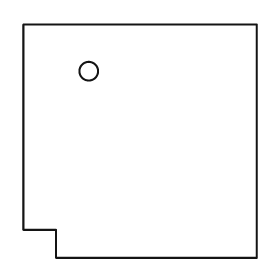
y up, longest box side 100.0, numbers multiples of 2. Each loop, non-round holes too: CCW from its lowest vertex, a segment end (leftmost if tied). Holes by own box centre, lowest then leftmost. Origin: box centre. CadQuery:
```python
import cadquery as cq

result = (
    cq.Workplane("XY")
    .moveTo(-36.0, -50.0)
    .lineTo(50.0, -50.0)
    .lineTo(50.0, 50.0)
    .lineTo(-50.0, 50.0)
    .lineTo(-50.0, -38.0)
    .lineTo(-36.0, -38.0)
    .close()
    .moveTo(-22.0, 30.0)
    .circle(4.0)
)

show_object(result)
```